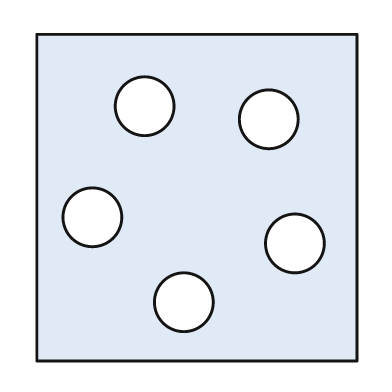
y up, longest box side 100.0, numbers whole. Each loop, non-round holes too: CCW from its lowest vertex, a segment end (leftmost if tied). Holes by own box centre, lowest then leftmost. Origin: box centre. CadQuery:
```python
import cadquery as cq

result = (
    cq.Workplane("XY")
    .moveTo(-49.0, -50.0)
    .lineTo(49.0, -50.0)
    .lineTo(49.0, 50.0)
    .lineTo(-49.0, 50.0)
    .close()
    .moveTo(-4.0, -32.0)
    .circle(9.0)
    .moveTo(30.0, -14.0)
    .circle(9.0)
    .moveTo(-32.0, -6.0)
    .circle(9.0)
    .moveTo(22.0, 24.0)
    .circle(9.0)
    .moveTo(-16.0, 28.0)
    .circle(9.0)
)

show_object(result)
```